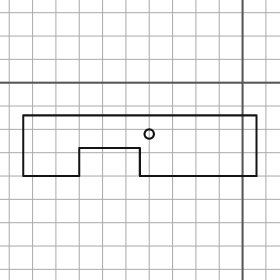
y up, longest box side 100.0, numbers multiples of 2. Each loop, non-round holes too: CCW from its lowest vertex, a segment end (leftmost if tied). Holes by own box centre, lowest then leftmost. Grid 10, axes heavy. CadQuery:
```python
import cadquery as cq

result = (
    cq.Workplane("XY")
    .moveTo(-94.0, -40.0)
    .lineTo(-70.0, -40.0)
    .lineTo(-70.0, -28.0)
    .lineTo(-44.0, -28.0)
    .lineTo(-44.0, -40.0)
    .lineTo(6.0, -40.0)
    .lineTo(6.0, -14.0)
    .lineTo(-94.0, -14.0)
    .close()
    .moveTo(-40.0, -22.0)
    .circle(2.0)
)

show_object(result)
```